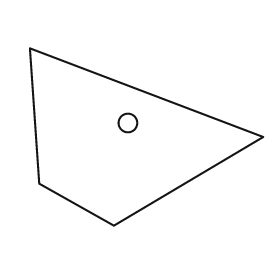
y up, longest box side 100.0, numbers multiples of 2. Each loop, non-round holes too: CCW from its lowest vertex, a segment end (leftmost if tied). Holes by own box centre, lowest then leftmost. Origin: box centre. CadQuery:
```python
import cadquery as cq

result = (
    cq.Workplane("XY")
    .moveTo(-14.0, -38.0)
    .lineTo(50.0, 0.0)
    .lineTo(-50.0, 38.0)
    .lineTo(-46.0, -20.0)
    .close()
    .moveTo(-8.0, 6.0)
    .circle(4.0)
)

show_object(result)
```